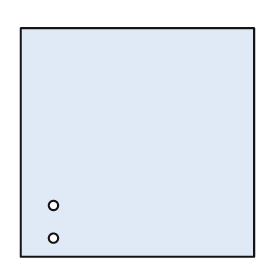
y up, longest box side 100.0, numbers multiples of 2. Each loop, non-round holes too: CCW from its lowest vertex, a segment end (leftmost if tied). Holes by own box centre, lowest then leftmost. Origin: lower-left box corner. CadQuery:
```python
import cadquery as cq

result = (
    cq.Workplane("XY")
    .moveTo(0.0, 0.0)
    .lineTo(100.0, 0.0)
    .lineTo(100.0, 98.0)
    .lineTo(0.0, 98.0)
    .close()
    .moveTo(14.0, 8.0)
    .circle(2.0)
    .moveTo(14.0, 22.0)
    .circle(2.0)
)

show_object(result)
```